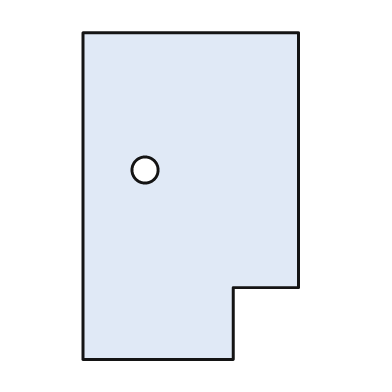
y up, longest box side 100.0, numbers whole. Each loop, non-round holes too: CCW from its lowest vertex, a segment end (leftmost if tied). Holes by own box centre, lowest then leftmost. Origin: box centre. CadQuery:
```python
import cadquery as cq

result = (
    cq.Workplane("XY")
    .moveTo(-33.0, -50.0)
    .lineTo(13.0, -50.0)
    .lineTo(13.0, -28.0)
    .lineTo(33.0, -28.0)
    .lineTo(33.0, 50.0)
    .lineTo(-33.0, 50.0)
    .close()
    .moveTo(-14.0, 8.0)
    .circle(4.0)
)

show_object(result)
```